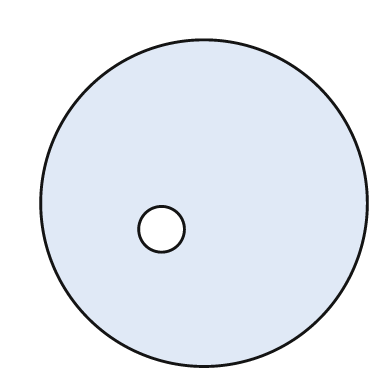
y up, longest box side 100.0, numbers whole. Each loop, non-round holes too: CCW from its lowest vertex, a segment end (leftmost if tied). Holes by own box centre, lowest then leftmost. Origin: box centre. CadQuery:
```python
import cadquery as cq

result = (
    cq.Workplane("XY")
    .moveTo(0.0, 0.0)
    .circle(50.0)
    .moveTo(-13.0, -8.0)
    .circle(7.0)
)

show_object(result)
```